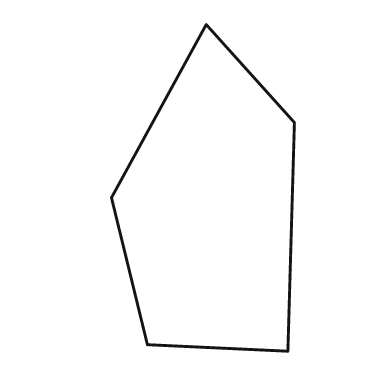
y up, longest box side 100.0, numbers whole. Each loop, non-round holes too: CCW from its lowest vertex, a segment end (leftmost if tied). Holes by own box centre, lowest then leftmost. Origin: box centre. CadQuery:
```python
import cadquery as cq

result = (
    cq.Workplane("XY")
    .moveTo(26.0, -50.0)
    .lineTo(28.0, 20.0)
    .lineTo(1.0, 50.0)
    .lineTo(-28.0, -3.0)
    .lineTo(-17.0, -48.0)
    .close()
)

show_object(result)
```